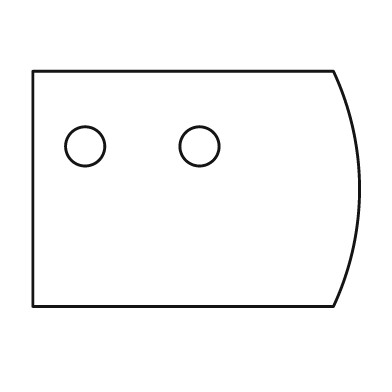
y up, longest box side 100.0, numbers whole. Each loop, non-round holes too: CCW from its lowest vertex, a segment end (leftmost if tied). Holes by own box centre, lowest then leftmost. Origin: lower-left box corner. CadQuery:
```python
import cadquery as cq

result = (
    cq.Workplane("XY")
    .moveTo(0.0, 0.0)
    .lineTo(92.0, 0.0)
    .threePointArc((100.0, 36.0), (92.0, 72.0))
    .lineTo(0.0, 72.0)
    .close()
    .moveTo(16.0, 49.0)
    .circle(6.0)
    .moveTo(51.0, 49.0)
    .circle(6.0)
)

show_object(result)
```